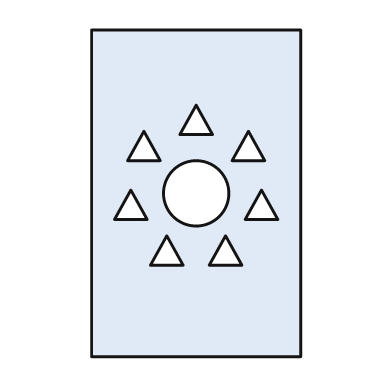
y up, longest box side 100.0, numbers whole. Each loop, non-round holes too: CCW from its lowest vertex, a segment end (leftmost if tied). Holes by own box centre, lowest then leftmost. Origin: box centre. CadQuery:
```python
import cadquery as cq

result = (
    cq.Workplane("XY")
    .moveTo(-32.0, -50.0)
    .lineTo(32.0, -50.0)
    .lineTo(32.0, 50.0)
    .lineTo(-32.0, 50.0)
    .close()
    .moveTo(-14.0, -22.0)
    .lineTo(-4.0, -22.0)
    .lineTo(-9.0, -13.0)
    .close()
    .moveTo(4.0, -22.0)
    .lineTo(14.0, -22.0)
    .lineTo(9.0, -13.0)
    .close()
    .moveTo(-25.0, -8.0)
    .lineTo(-15.0, -8.0)
    .lineTo(-20.0, 1.0)
    .close()
    .moveTo(15.0, -8.0)
    .lineTo(25.0, -8.0)
    .lineTo(20.0, 1.0)
    .close()
    .moveTo(0.0, 0.0)
    .circle(10.0)
    .moveTo(-21.0, 10.0)
    .lineTo(-11.0, 10.0)
    .lineTo(-16.0, 19.0)
    .close()
    .moveTo(11.0, 10.0)
    .lineTo(21.0, 10.0)
    .lineTo(16.0, 19.0)
    .close()
    .moveTo(-5.0, 18.0)
    .lineTo(5.0, 18.0)
    .lineTo(0.0, 27.0)
    .close()
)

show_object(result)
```